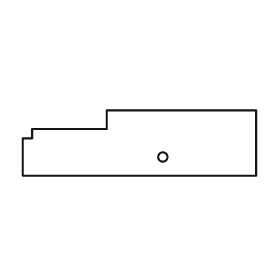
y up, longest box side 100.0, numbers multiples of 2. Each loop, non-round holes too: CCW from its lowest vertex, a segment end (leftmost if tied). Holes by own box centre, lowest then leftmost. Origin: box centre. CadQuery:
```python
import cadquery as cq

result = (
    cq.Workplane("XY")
    .moveTo(-50.0, -14.0)
    .lineTo(50.0, -14.0)
    .lineTo(50.0, 14.0)
    .lineTo(-14.0, 14.0)
    .lineTo(-14.0, 6.0)
    .lineTo(-46.0, 6.0)
    .lineTo(-46.0, 2.0)
    .lineTo(-50.0, 2.0)
    .close()
    .moveTo(10.0, -6.0)
    .circle(2.0)
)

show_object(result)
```